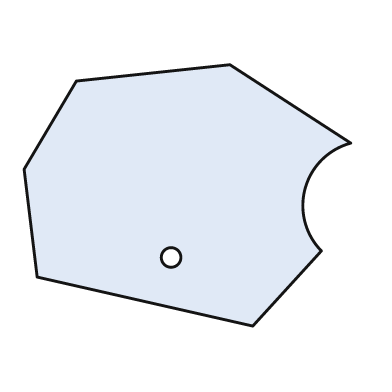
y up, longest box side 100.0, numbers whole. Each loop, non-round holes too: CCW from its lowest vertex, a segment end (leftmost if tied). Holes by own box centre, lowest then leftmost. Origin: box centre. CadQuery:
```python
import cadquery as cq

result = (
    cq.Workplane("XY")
    .moveTo(20.0, -40.0)
    .lineTo(41.0, -17.0)
    .threePointArc((36.0, 2.0), (50.0, 16.0))
    .lineTo(13.0, 40.0)
    .lineTo(-34.0, 35.0)
    .lineTo(-50.0, 8.0)
    .lineTo(-46.0, -25.0)
    .close()
    .moveTo(-5.0, -19.0)
    .circle(3.0)
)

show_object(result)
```